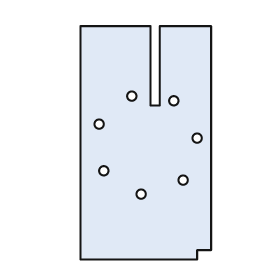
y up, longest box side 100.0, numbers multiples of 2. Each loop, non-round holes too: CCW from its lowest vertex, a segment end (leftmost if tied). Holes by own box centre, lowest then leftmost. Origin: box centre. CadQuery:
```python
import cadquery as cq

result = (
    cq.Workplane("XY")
    .moveTo(-28.0, -50.0)
    .lineTo(22.0, -50.0)
    .lineTo(22.0, -46.0)
    .lineTo(28.0, -46.0)
    .lineTo(28.0, 50.0)
    .lineTo(6.0, 50.0)
    .lineTo(6.0, 16.0)
    .lineTo(2.0, 16.0)
    .lineTo(2.0, 50.0)
    .lineTo(-28.0, 50.0)
    .close()
    .moveTo(-2.0, -22.0)
    .circle(2.0)
    .moveTo(16.0, -16.0)
    .circle(2.0)
    .moveTo(-18.0, -12.0)
    .circle(2.0)
    .moveTo(22.0, 2.0)
    .circle(2.0)
    .moveTo(-20.0, 8.0)
    .circle(2.0)
    .moveTo(12.0, 18.0)
    .circle(2.0)
    .moveTo(-6.0, 20.0)
    .circle(2.0)
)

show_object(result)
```